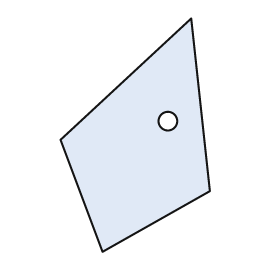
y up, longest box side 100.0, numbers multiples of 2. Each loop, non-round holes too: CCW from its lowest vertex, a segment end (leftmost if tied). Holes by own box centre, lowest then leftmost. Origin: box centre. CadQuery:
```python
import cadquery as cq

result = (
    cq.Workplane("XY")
    .moveTo(-14.0, -50.0)
    .lineTo(32.0, -24.0)
    .lineTo(24.0, 50.0)
    .lineTo(-32.0, -2.0)
    .close()
    .moveTo(14.0, 6.0)
    .circle(4.0)
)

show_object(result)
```